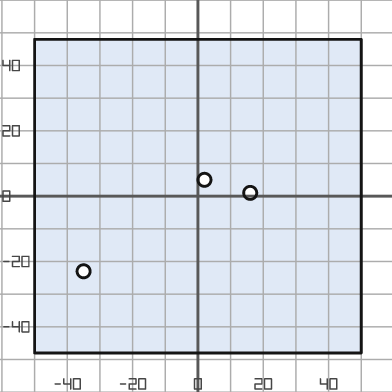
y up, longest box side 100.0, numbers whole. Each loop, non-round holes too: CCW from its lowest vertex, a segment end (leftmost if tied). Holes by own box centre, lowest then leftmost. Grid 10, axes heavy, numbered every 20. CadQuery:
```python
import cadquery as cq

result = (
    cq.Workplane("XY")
    .moveTo(-50.0, -48.0)
    .lineTo(50.0, -48.0)
    .lineTo(50.0, 48.0)
    .lineTo(-50.0, 48.0)
    .close()
    .moveTo(-35.0, -23.0)
    .circle(2.0)
    .moveTo(16.0, 1.0)
    .circle(2.0)
    .moveTo(2.0, 5.0)
    .circle(2.0)
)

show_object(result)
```